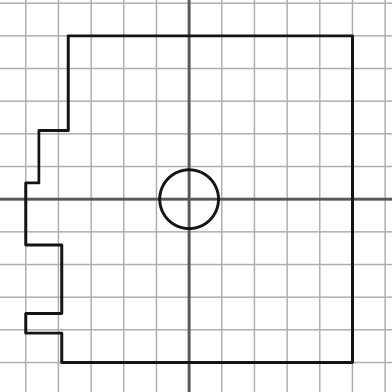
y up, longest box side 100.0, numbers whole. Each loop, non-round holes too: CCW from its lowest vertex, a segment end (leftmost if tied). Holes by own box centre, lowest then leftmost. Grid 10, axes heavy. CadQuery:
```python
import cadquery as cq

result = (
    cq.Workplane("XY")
    .moveTo(-39.0, -50.0)
    .lineTo(50.0, -50.0)
    .lineTo(50.0, 50.0)
    .lineTo(-37.0, 50.0)
    .lineTo(-37.0, 21.0)
    .lineTo(-46.0, 21.0)
    .lineTo(-46.0, 5.0)
    .lineTo(-50.0, 5.0)
    .lineTo(-50.0, -14.0)
    .lineTo(-39.0, -14.0)
    .lineTo(-39.0, -35.0)
    .lineTo(-50.0, -35.0)
    .lineTo(-50.0, -41.0)
    .lineTo(-39.0, -41.0)
    .close()
    .moveTo(0.0, 0.0)
    .circle(9.0)
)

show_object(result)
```